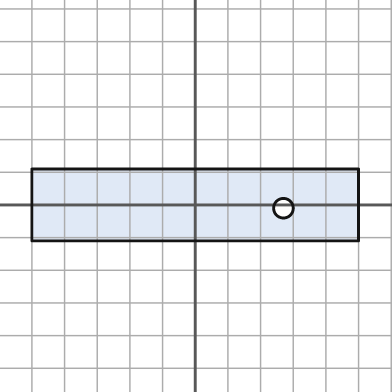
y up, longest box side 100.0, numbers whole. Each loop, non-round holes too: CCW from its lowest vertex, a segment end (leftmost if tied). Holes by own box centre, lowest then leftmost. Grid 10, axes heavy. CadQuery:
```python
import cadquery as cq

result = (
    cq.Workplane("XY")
    .moveTo(-50.0, -11.0)
    .lineTo(50.0, -11.0)
    .lineTo(50.0, 11.0)
    .lineTo(-50.0, 11.0)
    .close()
    .moveTo(27.0, -1.0)
    .circle(3.0)
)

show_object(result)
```